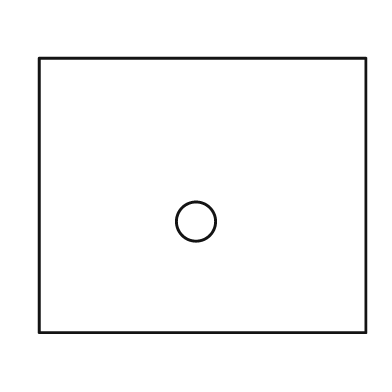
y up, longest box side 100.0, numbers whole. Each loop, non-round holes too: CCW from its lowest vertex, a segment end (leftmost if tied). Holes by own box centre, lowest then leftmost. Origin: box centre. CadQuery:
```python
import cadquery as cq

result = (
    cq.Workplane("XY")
    .moveTo(-50.0, -42.0)
    .lineTo(50.0, -42.0)
    .lineTo(50.0, 42.0)
    .lineTo(-50.0, 42.0)
    .close()
    .moveTo(-2.0, -8.0)
    .circle(6.0)
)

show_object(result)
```